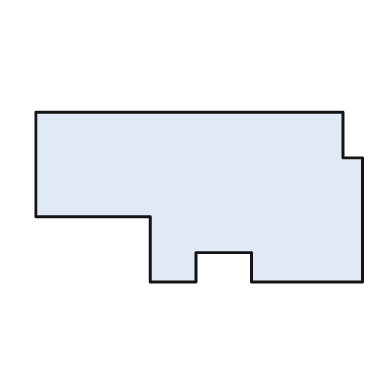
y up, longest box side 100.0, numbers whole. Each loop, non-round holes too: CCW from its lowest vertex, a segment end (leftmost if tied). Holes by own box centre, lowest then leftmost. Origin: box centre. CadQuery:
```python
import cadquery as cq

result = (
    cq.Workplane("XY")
    .moveTo(-15.0, -26.0)
    .lineTo(-1.0, -26.0)
    .lineTo(-1.0, -17.0)
    .lineTo(16.0, -17.0)
    .lineTo(16.0, -26.0)
    .lineTo(50.0, -26.0)
    .lineTo(50.0, 12.0)
    .lineTo(44.0, 12.0)
    .lineTo(44.0, 26.0)
    .lineTo(-50.0, 26.0)
    .lineTo(-50.0, -6.0)
    .lineTo(-15.0, -6.0)
    .close()
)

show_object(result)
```